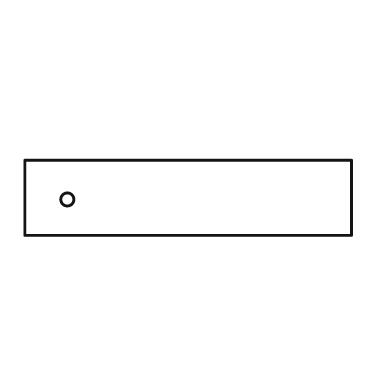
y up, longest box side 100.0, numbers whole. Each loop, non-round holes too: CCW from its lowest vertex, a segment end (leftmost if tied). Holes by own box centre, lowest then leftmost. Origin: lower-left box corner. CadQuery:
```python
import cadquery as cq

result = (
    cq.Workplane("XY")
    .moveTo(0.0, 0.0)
    .lineTo(100.0, 0.0)
    .lineTo(100.0, 23.0)
    .lineTo(0.0, 23.0)
    .close()
    .moveTo(13.0, 11.0)
    .circle(2.0)
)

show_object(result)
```